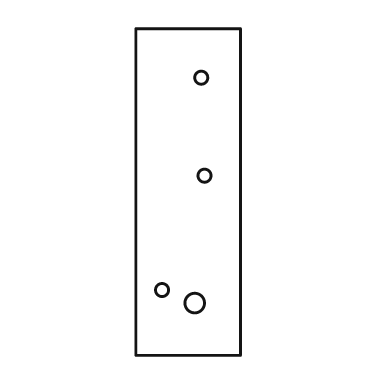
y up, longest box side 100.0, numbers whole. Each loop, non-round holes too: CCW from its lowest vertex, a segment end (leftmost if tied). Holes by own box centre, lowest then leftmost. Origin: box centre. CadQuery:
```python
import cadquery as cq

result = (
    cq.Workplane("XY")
    .moveTo(-16.0, -50.0)
    .lineTo(16.0, -50.0)
    .lineTo(16.0, 50.0)
    .lineTo(-16.0, 50.0)
    .close()
    .moveTo(2.0, -34.0)
    .circle(3.0)
    .moveTo(-8.0, -30.0)
    .circle(2.0)
    .moveTo(5.0, 5.0)
    .circle(2.0)
    .moveTo(4.0, 35.0)
    .circle(2.0)
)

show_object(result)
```